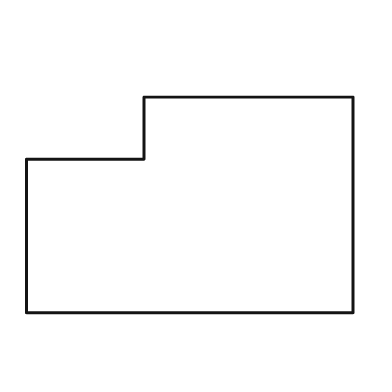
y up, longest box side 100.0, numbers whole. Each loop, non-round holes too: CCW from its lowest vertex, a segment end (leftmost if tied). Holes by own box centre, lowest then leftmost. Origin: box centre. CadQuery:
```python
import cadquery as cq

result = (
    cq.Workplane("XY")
    .moveTo(-50.0, -33.0)
    .lineTo(50.0, -33.0)
    .lineTo(50.0, 33.0)
    .lineTo(-14.0, 33.0)
    .lineTo(-14.0, 14.0)
    .lineTo(-50.0, 14.0)
    .close()
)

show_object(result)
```